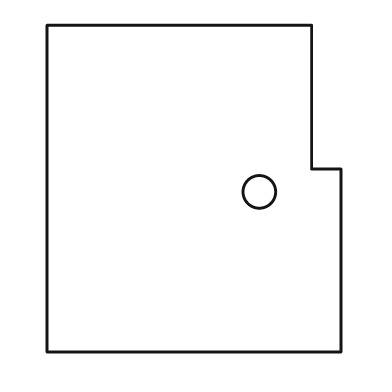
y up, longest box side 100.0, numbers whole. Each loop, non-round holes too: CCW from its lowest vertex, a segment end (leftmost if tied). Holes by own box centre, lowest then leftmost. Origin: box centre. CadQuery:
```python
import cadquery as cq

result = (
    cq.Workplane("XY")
    .moveTo(-45.0, -50.0)
    .lineTo(45.0, -50.0)
    .lineTo(45.0, 6.0)
    .lineTo(36.0, 6.0)
    .lineTo(36.0, 50.0)
    .lineTo(-45.0, 50.0)
    .close()
    .moveTo(20.0, -1.0)
    .circle(5.0)
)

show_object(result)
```